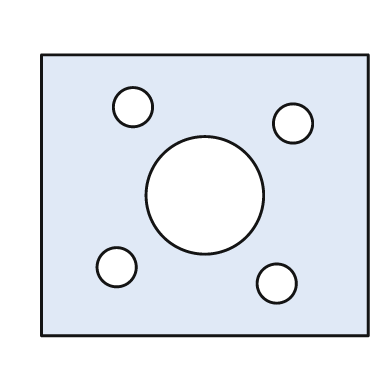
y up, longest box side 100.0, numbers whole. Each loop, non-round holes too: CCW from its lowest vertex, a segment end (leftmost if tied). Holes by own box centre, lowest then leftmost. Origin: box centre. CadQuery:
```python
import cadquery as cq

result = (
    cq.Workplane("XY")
    .moveTo(-50.0, -43.0)
    .lineTo(50.0, -43.0)
    .lineTo(50.0, 43.0)
    .lineTo(-50.0, 43.0)
    .close()
    .moveTo(22.0, -27.0)
    .circle(6.0)
    .moveTo(-27.0, -22.0)
    .circle(6.0)
    .moveTo(0.0, 0.0)
    .circle(18.0)
    .moveTo(27.0, 22.0)
    .circle(6.0)
    .moveTo(-22.0, 27.0)
    .circle(6.0)
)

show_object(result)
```